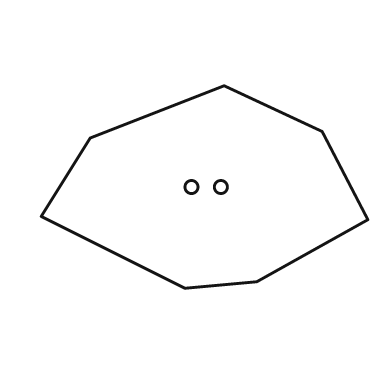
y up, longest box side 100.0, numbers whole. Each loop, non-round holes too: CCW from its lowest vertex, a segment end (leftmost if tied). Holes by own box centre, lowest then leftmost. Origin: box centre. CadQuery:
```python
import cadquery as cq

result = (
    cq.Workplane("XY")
    .moveTo(-6.0, -31.0)
    .lineTo(16.0, -29.0)
    .lineTo(50.0, -10.0)
    .lineTo(36.0, 17.0)
    .lineTo(6.0, 31.0)
    .lineTo(-35.0, 15.0)
    .lineTo(-50.0, -9.0)
    .close()
    .moveTo(-4.0, 0.0)
    .circle(2.0)
    .moveTo(5.0, 0.0)
    .circle(2.0)
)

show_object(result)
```